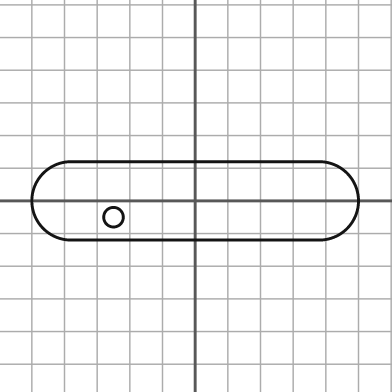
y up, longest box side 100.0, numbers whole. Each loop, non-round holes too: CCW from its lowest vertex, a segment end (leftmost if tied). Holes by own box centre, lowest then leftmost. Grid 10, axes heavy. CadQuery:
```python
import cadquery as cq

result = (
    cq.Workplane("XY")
    .moveTo(-38.0, -12.0)
    .lineTo(38.0, -12.0)
    .threePointArc((50.0, 0.0), (38.0, 12.0))
    .lineTo(-38.0, 12.0)
    .threePointArc((-50.0, 0.0), (-38.0, -12.0))
    .close()
    .moveTo(-25.0, -5.0)
    .circle(3.0)
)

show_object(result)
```